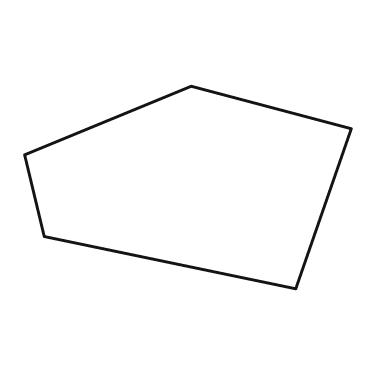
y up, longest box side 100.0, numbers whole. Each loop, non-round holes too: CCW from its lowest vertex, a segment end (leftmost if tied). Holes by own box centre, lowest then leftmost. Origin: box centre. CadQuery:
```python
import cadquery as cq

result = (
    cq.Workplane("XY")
    .moveTo(33.0, -31.0)
    .lineTo(50.0, 18.0)
    .lineTo(1.0, 31.0)
    .lineTo(-50.0, 10.0)
    .lineTo(-44.0, -15.0)
    .close()
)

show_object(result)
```